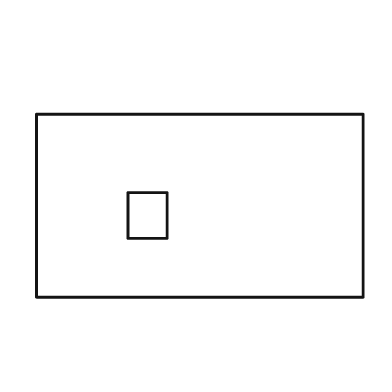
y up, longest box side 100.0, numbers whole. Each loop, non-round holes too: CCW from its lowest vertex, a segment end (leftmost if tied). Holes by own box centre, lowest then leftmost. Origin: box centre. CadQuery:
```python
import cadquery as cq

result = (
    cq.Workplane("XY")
    .moveTo(-50.0, -28.0)
    .lineTo(50.0, -28.0)
    .lineTo(50.0, 28.0)
    .lineTo(-50.0, 28.0)
    .close()
    .moveTo(-22.0, -10.0)
    .lineTo(-10.0, -10.0)
    .lineTo(-10.0, 4.0)
    .lineTo(-22.0, 4.0)
    .close()
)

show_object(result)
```